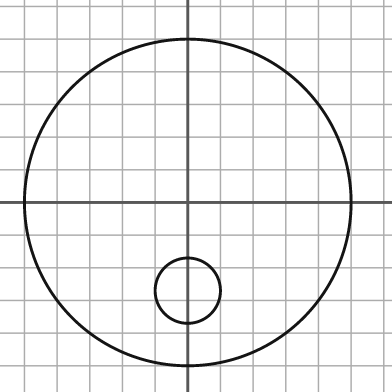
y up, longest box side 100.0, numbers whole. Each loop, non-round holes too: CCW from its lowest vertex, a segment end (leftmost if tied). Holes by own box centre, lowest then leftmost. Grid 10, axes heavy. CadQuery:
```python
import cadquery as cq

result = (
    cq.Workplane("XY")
    .moveTo(0.0, 0.0)
    .circle(50.0)
    .moveTo(0.0, -27.0)
    .circle(10.0)
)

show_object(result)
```